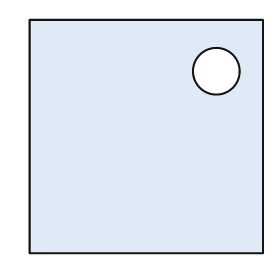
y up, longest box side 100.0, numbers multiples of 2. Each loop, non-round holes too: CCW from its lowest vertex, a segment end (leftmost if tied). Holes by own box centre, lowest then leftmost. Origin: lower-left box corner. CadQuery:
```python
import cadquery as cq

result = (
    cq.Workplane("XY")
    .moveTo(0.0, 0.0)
    .lineTo(100.0, 0.0)
    .lineTo(100.0, 100.0)
    .lineTo(0.0, 100.0)
    .close()
    .moveTo(80.0, 78.0)
    .circle(10.0)
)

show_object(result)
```